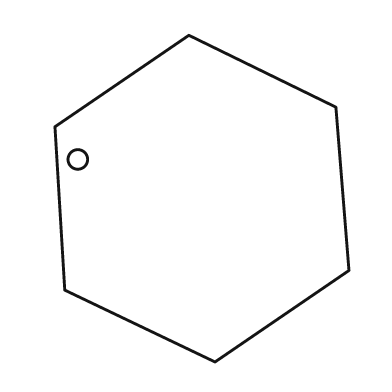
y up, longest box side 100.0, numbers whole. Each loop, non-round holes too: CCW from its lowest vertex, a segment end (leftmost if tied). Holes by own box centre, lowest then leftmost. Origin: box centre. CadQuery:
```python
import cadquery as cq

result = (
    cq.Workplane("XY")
    .moveTo(4.0, -50.0)
    .lineTo(45.0, -22.0)
    .lineTo(41.0, 28.0)
    .lineTo(-4.0, 50.0)
    .lineTo(-45.0, 22.0)
    .lineTo(-42.0, -28.0)
    .close()
    .moveTo(-38.0, 12.0)
    .circle(3.0)
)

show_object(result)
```